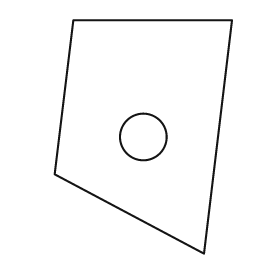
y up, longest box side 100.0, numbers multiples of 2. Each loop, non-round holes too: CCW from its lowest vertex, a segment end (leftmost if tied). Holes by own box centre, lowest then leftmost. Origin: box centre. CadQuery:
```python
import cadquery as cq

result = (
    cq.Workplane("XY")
    .moveTo(26.0, -50.0)
    .lineTo(38.0, 50.0)
    .lineTo(-30.0, 50.0)
    .lineTo(-38.0, -16.0)
    .close()
    .moveTo(0.0, 0.0)
    .circle(10.0)
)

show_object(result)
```